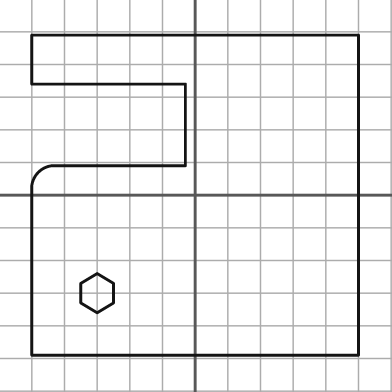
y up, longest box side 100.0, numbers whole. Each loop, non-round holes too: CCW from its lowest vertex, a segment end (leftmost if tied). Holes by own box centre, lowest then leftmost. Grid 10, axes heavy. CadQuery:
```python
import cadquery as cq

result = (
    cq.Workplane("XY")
    .moveTo(-50.0, -49.0)
    .lineTo(50.0, -49.0)
    .lineTo(50.0, 49.0)
    .lineTo(-50.0, 49.0)
    .lineTo(-50.0, 34.0)
    .lineTo(-3.0, 34.0)
    .lineTo(-3.0, 9.0)
    .lineTo(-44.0, 9.0)
    .threePointArc((-48.0, 7.0), (-50.0, 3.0))
    .close()
    .moveTo(-30.0, -36.0)
    .lineTo(-25.0, -33.0)
    .lineTo(-25.0, -27.0)
    .lineTo(-30.0, -24.0)
    .lineTo(-35.0, -27.0)
    .lineTo(-35.0, -33.0)
    .close()
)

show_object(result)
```